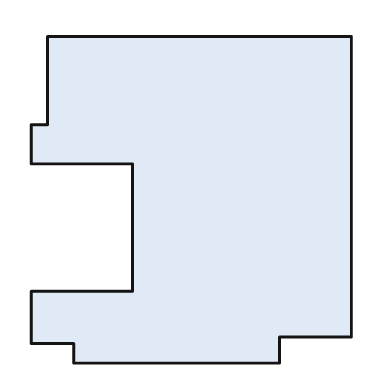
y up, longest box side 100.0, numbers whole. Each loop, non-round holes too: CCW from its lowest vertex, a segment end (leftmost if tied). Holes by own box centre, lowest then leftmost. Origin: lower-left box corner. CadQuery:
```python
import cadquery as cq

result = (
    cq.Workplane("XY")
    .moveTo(13.0, 0.0)
    .lineTo(76.0, 0.0)
    .lineTo(76.0, 8.0)
    .lineTo(98.0, 8.0)
    .lineTo(98.0, 100.0)
    .lineTo(5.0, 100.0)
    .lineTo(5.0, 73.0)
    .lineTo(0.0, 73.0)
    .lineTo(0.0, 61.0)
    .lineTo(31.0, 61.0)
    .lineTo(31.0, 22.0)
    .lineTo(0.0, 22.0)
    .lineTo(0.0, 6.0)
    .lineTo(13.0, 6.0)
    .close()
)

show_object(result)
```